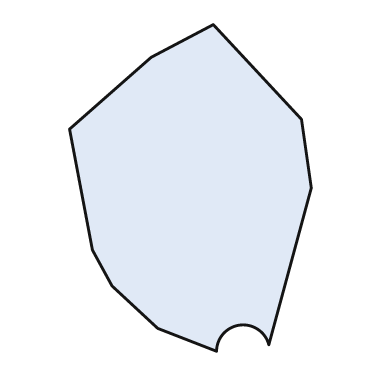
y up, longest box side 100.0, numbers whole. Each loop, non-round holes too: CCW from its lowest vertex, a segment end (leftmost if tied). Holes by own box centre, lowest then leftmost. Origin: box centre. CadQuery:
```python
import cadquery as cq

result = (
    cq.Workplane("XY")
    .moveTo(8.0, -50.0)
    .threePointArc((15.0, -42.0), (24.0, -48.0))
    .lineTo(37.0, 0.0)
    .lineTo(34.0, 21.0)
    .lineTo(7.0, 50.0)
    .lineTo(-12.0, 40.0)
    .lineTo(-37.0, 18.0)
    .lineTo(-30.0, -19.0)
    .lineTo(-24.0, -30.0)
    .lineTo(-10.0, -43.0)
    .close()
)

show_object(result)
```